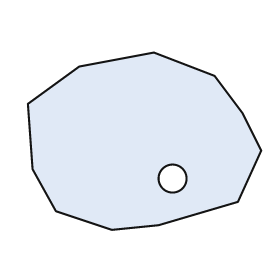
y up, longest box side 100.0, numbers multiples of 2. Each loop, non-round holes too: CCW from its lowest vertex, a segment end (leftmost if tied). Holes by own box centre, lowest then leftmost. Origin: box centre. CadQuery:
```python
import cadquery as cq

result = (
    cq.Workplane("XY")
    .moveTo(-14.0, -38.0)
    .lineTo(6.0, -36.0)
    .lineTo(40.0, -26.0)
    .lineTo(50.0, -4.0)
    .lineTo(42.0, 12.0)
    .lineTo(30.0, 28.0)
    .lineTo(4.0, 38.0)
    .lineTo(-28.0, 32.0)
    .lineTo(-50.0, 16.0)
    .lineTo(-48.0, -12.0)
    .lineTo(-38.0, -30.0)
    .close()
    .moveTo(12.0, -16.0)
    .circle(6.0)
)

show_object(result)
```